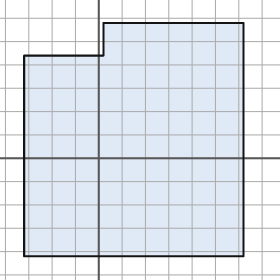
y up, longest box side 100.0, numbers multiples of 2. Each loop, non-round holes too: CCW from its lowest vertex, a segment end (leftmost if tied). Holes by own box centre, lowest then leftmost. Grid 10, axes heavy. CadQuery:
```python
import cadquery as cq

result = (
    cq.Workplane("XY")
    .moveTo(-32.0, -42.0)
    .lineTo(62.0, -42.0)
    .lineTo(62.0, 58.0)
    .lineTo(2.0, 58.0)
    .lineTo(2.0, 44.0)
    .lineTo(-32.0, 44.0)
    .close()
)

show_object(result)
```